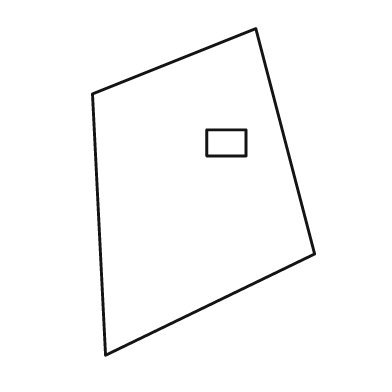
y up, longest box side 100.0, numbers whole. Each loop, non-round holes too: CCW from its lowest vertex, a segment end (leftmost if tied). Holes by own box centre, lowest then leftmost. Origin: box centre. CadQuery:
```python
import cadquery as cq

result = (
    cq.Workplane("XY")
    .moveTo(-30.0, -50.0)
    .lineTo(34.0, -19.0)
    .lineTo(16.0, 50.0)
    .lineTo(-34.0, 30.0)
    .close()
    .moveTo(1.0, 11.0)
    .lineTo(13.0, 11.0)
    .lineTo(13.0, 19.0)
    .lineTo(1.0, 19.0)
    .close()
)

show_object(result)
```